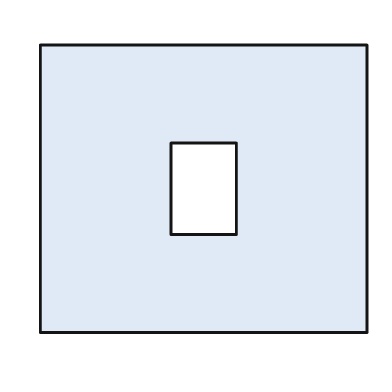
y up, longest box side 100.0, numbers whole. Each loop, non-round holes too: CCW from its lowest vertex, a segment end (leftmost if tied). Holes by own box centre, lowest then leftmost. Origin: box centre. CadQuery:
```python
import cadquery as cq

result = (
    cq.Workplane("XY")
    .moveTo(-50.0, -44.0)
    .lineTo(50.0, -44.0)
    .lineTo(50.0, 44.0)
    .lineTo(-50.0, 44.0)
    .close()
    .moveTo(-10.0, -14.0)
    .lineTo(10.0, -14.0)
    .lineTo(10.0, 14.0)
    .lineTo(-10.0, 14.0)
    .close()
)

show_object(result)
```